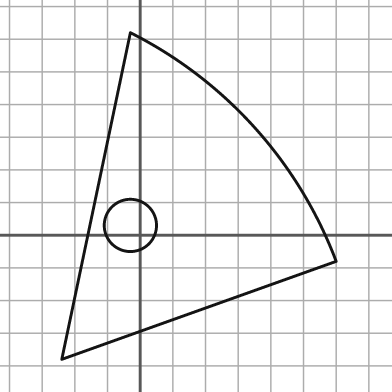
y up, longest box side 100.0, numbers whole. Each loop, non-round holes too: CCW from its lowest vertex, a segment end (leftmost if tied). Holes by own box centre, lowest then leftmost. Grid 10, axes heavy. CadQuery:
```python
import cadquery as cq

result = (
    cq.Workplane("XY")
    .moveTo(-24.0, -38.0)
    .lineTo(60.0, -8.0)
    .threePointArc((35.0, 33.0), (-3.0, 62.0))
    .close()
    .moveTo(-3.0, 3.0)
    .circle(8.0)
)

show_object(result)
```